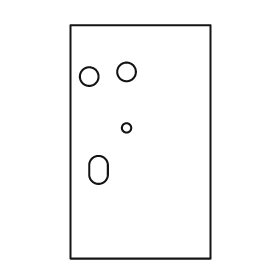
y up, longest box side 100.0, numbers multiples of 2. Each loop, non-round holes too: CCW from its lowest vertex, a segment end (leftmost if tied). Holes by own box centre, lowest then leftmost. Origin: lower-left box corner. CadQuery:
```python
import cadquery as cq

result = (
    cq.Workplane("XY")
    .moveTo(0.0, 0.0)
    .lineTo(60.0, 0.0)
    .lineTo(60.0, 100.0)
    .lineTo(0.0, 100.0)
    .close()
    .moveTo(8.0, 36.0)
    .threePointArc((12.0, 32.0), (16.0, 36.0))
    .lineTo(16.0, 40.0)
    .threePointArc((12.0, 44.0), (8.0, 40.0))
    .close()
    .moveTo(24.0, 56.0)
    .circle(2.0)
    .moveTo(8.0, 78.0)
    .circle(4.0)
    .moveTo(24.0, 80.0)
    .circle(4.0)
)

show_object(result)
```